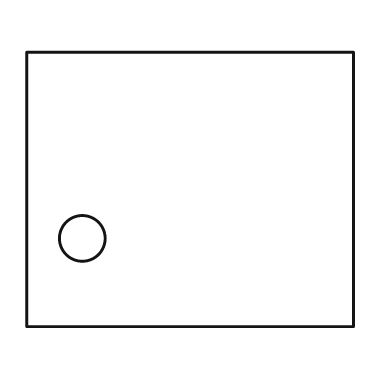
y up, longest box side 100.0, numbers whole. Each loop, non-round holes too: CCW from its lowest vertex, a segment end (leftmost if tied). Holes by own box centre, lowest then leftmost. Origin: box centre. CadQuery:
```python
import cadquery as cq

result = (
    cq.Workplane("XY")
    .moveTo(-50.0, -42.0)
    .lineTo(50.0, -42.0)
    .lineTo(50.0, 42.0)
    .lineTo(-50.0, 42.0)
    .close()
    .moveTo(-33.0, -15.0)
    .circle(7.0)
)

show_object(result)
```